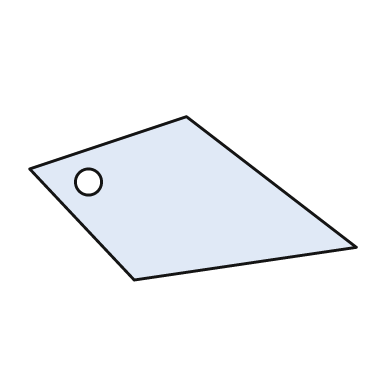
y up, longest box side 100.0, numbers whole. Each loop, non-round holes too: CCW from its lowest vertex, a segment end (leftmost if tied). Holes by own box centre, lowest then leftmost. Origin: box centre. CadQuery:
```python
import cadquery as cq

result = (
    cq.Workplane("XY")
    .moveTo(-18.0, -25.0)
    .lineTo(50.0, -15.0)
    .lineTo(-2.0, 25.0)
    .lineTo(-50.0, 9.0)
    .close()
    .moveTo(-32.0, 5.0)
    .circle(4.0)
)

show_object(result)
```